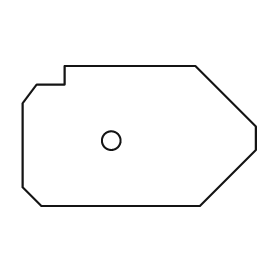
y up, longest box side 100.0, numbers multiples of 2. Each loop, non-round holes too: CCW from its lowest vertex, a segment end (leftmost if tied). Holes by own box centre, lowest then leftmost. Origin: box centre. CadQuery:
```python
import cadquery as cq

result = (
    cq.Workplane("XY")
    .moveTo(-42.0, -30.0)
    .lineTo(26.0, -30.0)
    .lineTo(50.0, -6.0)
    .lineTo(50.0, 4.0)
    .lineTo(24.0, 30.0)
    .lineTo(-32.0, 30.0)
    .lineTo(-32.0, 22.0)
    .lineTo(-44.0, 22.0)
    .lineTo(-50.0, 14.0)
    .lineTo(-50.0, -22.0)
    .close()
    .moveTo(-12.0, -2.0)
    .circle(4.0)
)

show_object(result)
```